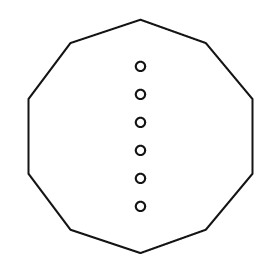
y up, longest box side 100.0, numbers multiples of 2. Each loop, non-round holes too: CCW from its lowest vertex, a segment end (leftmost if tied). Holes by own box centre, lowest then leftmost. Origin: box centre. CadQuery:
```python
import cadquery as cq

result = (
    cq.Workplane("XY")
    .moveTo(0.0, -50.0)
    .lineTo(28.0, -40.0)
    .lineTo(48.0, -16.0)
    .lineTo(48.0, 16.0)
    .lineTo(28.0, 40.0)
    .lineTo(0.0, 50.0)
    .lineTo(-30.0, 40.0)
    .lineTo(-48.0, 16.0)
    .lineTo(-48.0, -16.0)
    .lineTo(-30.0, -40.0)
    .close()
    .moveTo(0.0, -30.0)
    .circle(2.0)
    .moveTo(0.0, -18.0)
    .circle(2.0)
    .moveTo(0.0, -6.0)
    .circle(2.0)
    .moveTo(0.0, 6.0)
    .circle(2.0)
    .moveTo(0.0, 18.0)
    .circle(2.0)
    .moveTo(0.0, 30.0)
    .circle(2.0)
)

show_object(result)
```